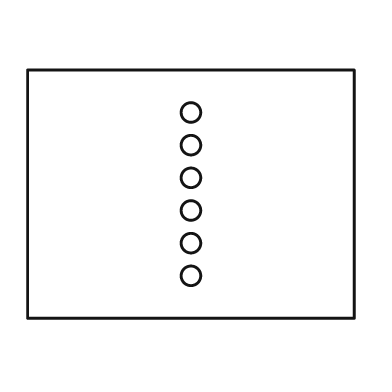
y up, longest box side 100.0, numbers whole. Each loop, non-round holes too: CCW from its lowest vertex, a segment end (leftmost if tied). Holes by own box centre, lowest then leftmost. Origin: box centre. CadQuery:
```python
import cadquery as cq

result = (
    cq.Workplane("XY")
    .moveTo(-50.0, -38.0)
    .lineTo(50.0, -38.0)
    .lineTo(50.0, 38.0)
    .lineTo(-50.0, 38.0)
    .close()
    .moveTo(0.0, -25.0)
    .circle(3.0)
    .moveTo(0.0, -15.0)
    .circle(3.0)
    .moveTo(0.0, -5.0)
    .circle(3.0)
    .moveTo(0.0, 5.0)
    .circle(3.0)
    .moveTo(0.0, 15.0)
    .circle(3.0)
    .moveTo(0.0, 25.0)
    .circle(3.0)
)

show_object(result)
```